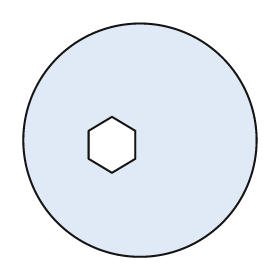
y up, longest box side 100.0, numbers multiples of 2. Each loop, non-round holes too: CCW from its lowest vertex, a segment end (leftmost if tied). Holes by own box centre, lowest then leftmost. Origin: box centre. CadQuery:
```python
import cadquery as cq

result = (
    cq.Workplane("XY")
    .moveTo(0.0, 0.0)
    .circle(50.0)
    .moveTo(-12.0, -14.0)
    .lineTo(-2.0, -8.0)
    .lineTo(-2.0, 4.0)
    .lineTo(-12.0, 10.0)
    .lineTo(-22.0, 4.0)
    .lineTo(-22.0, -8.0)
    .close()
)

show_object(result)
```